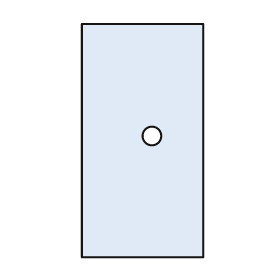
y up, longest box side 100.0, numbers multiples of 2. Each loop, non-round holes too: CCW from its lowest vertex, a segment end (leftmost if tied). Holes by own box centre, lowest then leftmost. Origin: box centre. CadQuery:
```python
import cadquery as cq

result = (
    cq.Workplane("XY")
    .moveTo(-26.0, -50.0)
    .lineTo(26.0, -50.0)
    .lineTo(26.0, 50.0)
    .lineTo(-26.0, 50.0)
    .close()
    .moveTo(4.0, 2.0)
    .circle(4.0)
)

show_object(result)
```